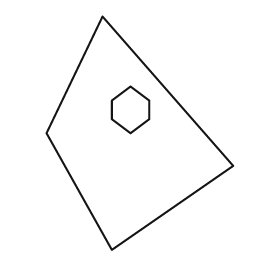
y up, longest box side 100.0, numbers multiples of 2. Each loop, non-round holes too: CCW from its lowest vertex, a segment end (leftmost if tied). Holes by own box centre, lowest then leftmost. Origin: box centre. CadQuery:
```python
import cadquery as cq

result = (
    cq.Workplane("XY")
    .moveTo(-12.0, -50.0)
    .lineTo(40.0, -14.0)
    .lineTo(-16.0, 50.0)
    .lineTo(-40.0, 0.0)
    .close()
    .moveTo(-4.0, 0.0)
    .lineTo(4.0, 6.0)
    .lineTo(4.0, 14.0)
    .lineTo(-4.0, 20.0)
    .lineTo(-12.0, 14.0)
    .lineTo(-12.0, 6.0)
    .close()
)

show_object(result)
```